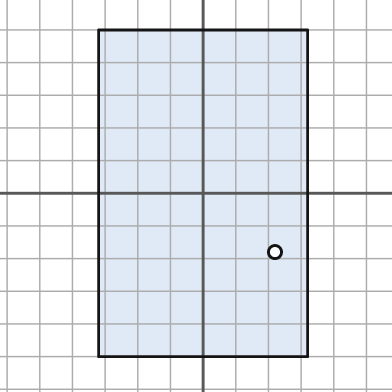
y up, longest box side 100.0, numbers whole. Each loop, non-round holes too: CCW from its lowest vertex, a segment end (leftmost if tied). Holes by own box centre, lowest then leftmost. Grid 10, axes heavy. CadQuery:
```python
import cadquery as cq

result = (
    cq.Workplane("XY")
    .moveTo(-32.0, -50.0)
    .lineTo(32.0, -50.0)
    .lineTo(32.0, 50.0)
    .lineTo(-32.0, 50.0)
    .close()
    .moveTo(22.0, -18.0)
    .circle(2.0)
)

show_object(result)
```